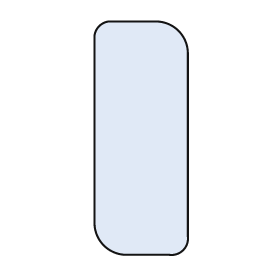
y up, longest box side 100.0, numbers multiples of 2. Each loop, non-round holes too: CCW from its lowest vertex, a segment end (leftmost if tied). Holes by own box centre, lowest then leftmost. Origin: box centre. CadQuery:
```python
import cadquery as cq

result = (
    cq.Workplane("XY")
    .moveTo(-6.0, -50.0)
    .lineTo(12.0, -50.0)
    .threePointArc((18.0, -48.0), (20.0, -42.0))
    .lineTo(20.0, 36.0)
    .threePointArc((16.0, 46.0), (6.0, 50.0))
    .lineTo(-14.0, 50.0)
    .threePointArc((-18.0, 48.0), (-20.0, 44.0))
    .lineTo(-20.0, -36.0)
    .threePointArc((-16.0, -46.0), (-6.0, -50.0))
    .close()
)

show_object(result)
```